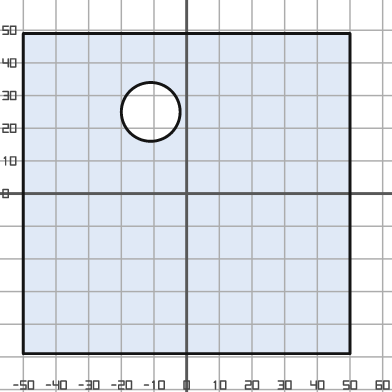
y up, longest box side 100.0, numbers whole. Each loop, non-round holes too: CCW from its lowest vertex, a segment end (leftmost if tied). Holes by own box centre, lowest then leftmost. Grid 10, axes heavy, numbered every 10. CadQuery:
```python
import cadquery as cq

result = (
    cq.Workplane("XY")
    .moveTo(-50.0, -49.0)
    .lineTo(50.0, -49.0)
    .lineTo(50.0, 49.0)
    .lineTo(-50.0, 49.0)
    .close()
    .moveTo(-11.0, 25.0)
    .circle(9.0)
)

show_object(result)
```